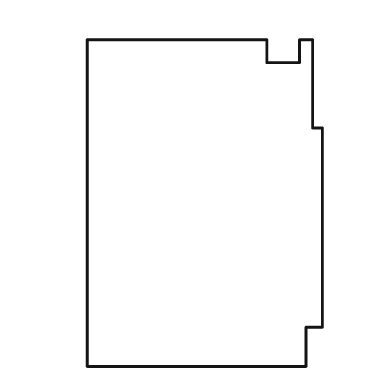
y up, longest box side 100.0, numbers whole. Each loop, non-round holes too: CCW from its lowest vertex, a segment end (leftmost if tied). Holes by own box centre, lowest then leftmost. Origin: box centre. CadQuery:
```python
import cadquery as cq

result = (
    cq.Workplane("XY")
    .moveTo(-36.0, -50.0)
    .lineTo(31.0, -50.0)
    .lineTo(31.0, -38.0)
    .lineTo(36.0, -38.0)
    .lineTo(36.0, 23.0)
    .lineTo(33.0, 23.0)
    .lineTo(33.0, 50.0)
    .lineTo(29.0, 50.0)
    .lineTo(29.0, 43.0)
    .lineTo(19.0, 43.0)
    .lineTo(19.0, 50.0)
    .lineTo(-36.0, 50.0)
    .close()
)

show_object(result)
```